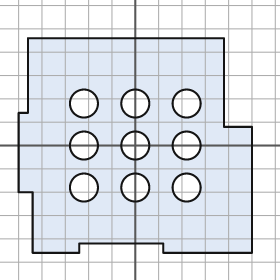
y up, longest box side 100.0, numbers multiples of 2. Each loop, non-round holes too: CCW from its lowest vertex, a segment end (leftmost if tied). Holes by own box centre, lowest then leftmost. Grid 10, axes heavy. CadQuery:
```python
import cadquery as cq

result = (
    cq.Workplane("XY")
    .moveTo(-44.0, -46.0)
    .lineTo(-24.0, -46.0)
    .lineTo(-24.0, -42.0)
    .lineTo(12.0, -42.0)
    .lineTo(12.0, -46.0)
    .lineTo(50.0, -46.0)
    .lineTo(50.0, 8.0)
    .lineTo(38.0, 8.0)
    .lineTo(38.0, 46.0)
    .lineTo(-46.0, 46.0)
    .lineTo(-46.0, 14.0)
    .lineTo(-50.0, 14.0)
    .lineTo(-50.0, -20.0)
    .lineTo(-44.0, -20.0)
    .close()
    .moveTo(-22.0, -18.0)
    .circle(6.0)
    .moveTo(0.0, -18.0)
    .circle(6.0)
    .moveTo(22.0, -18.0)
    .circle(6.0)
    .moveTo(-22.0, 0.0)
    .circle(6.0)
    .moveTo(0.0, 0.0)
    .circle(6.0)
    .moveTo(22.0, 0.0)
    .circle(6.0)
    .moveTo(-22.0, 18.0)
    .circle(6.0)
    .moveTo(0.0, 18.0)
    .circle(6.0)
    .moveTo(22.0, 18.0)
    .circle(6.0)
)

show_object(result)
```